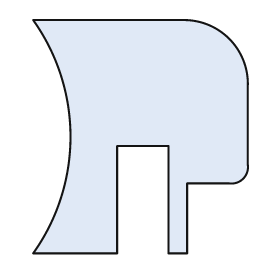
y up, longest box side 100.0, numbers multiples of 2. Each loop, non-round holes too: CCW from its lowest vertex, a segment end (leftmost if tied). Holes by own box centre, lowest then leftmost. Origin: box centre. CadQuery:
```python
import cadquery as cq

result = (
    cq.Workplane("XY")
    .moveTo(-46.0, -50.0)
    .lineTo(-10.0, -50.0)
    .lineTo(-10.0, -4.0)
    .lineTo(12.0, -4.0)
    .lineTo(12.0, -50.0)
    .lineTo(20.0, -50.0)
    .lineTo(20.0, -20.0)
    .lineTo(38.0, -20.0)
    .threePointArc((44.0, -18.0), (46.0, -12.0))
    .lineTo(46.0, 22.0)
    .threePointArc((38.0, 42.0), (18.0, 50.0))
    .lineTo(-46.0, 50.0)
    .threePointArc((-30.0, 0.0), (-46.0, -50.0))
    .close()
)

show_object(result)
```